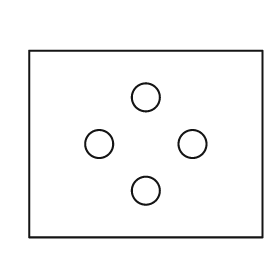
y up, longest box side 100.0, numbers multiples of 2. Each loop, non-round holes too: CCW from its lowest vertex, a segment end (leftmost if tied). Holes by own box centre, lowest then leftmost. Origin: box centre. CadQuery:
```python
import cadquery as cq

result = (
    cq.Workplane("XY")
    .moveTo(-50.0, -40.0)
    .lineTo(50.0, -40.0)
    .lineTo(50.0, 40.0)
    .lineTo(-50.0, 40.0)
    .close()
    .moveTo(0.0, -20.0)
    .circle(6.0)
    .moveTo(-20.0, 0.0)
    .circle(6.0)
    .moveTo(20.0, 0.0)
    .circle(6.0)
    .moveTo(0.0, 20.0)
    .circle(6.0)
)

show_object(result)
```